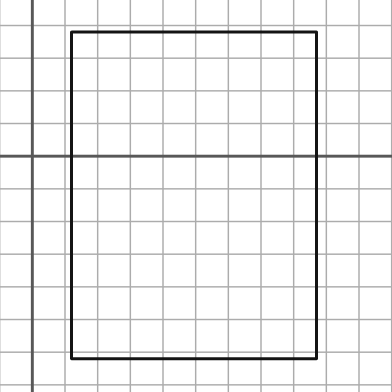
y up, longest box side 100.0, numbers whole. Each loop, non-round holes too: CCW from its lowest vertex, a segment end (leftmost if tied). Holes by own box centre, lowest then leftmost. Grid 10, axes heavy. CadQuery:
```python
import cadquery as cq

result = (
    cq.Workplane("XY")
    .moveTo(12.0, -62.0)
    .lineTo(87.0, -62.0)
    .lineTo(87.0, 38.0)
    .lineTo(12.0, 38.0)
    .close()
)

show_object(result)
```